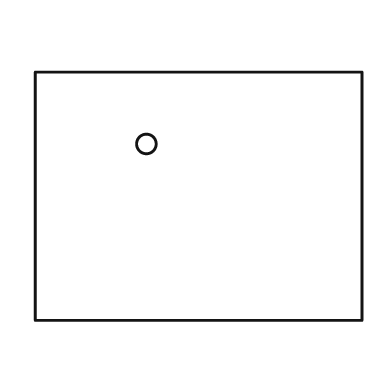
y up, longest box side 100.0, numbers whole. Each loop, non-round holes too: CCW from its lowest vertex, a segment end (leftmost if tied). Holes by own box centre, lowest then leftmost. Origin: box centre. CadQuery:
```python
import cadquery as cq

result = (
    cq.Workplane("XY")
    .moveTo(-50.0, -38.0)
    .lineTo(50.0, -38.0)
    .lineTo(50.0, 38.0)
    .lineTo(-50.0, 38.0)
    .close()
    .moveTo(-16.0, 16.0)
    .circle(3.0)
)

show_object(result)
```